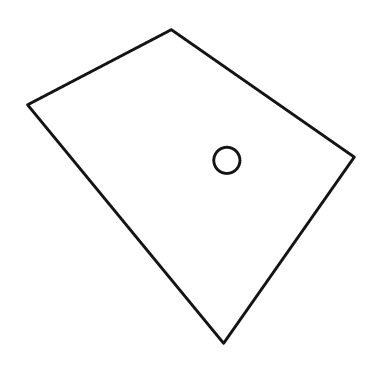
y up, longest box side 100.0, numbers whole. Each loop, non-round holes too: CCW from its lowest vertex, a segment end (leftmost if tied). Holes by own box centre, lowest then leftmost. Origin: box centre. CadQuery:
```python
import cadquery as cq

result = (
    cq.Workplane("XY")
    .moveTo(10.0, -48.0)
    .lineTo(50.0, 9.0)
    .lineTo(-6.0, 48.0)
    .lineTo(-50.0, 25.0)
    .close()
    .moveTo(11.0, 8.0)
    .circle(4.0)
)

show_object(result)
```